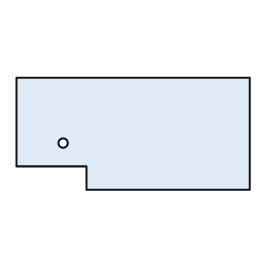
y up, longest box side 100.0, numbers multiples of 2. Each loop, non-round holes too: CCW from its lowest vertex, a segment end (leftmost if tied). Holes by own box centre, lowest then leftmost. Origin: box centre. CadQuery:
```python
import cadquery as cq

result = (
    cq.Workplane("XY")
    .moveTo(-20.0, -24.0)
    .lineTo(50.0, -24.0)
    .lineTo(50.0, 24.0)
    .lineTo(-50.0, 24.0)
    .lineTo(-50.0, -14.0)
    .lineTo(-20.0, -14.0)
    .close()
    .moveTo(-30.0, -4.0)
    .circle(2.0)
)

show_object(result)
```